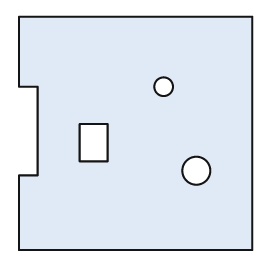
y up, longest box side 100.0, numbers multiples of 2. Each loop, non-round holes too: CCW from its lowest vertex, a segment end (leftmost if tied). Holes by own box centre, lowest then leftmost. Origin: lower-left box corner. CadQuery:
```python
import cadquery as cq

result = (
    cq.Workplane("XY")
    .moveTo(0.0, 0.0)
    .lineTo(100.0, 0.0)
    .lineTo(100.0, 100.0)
    .lineTo(0.0, 100.0)
    .lineTo(0.0, 70.0)
    .lineTo(8.0, 70.0)
    .lineTo(8.0, 32.0)
    .lineTo(0.0, 32.0)
    .close()
    .moveTo(76.0, 34.0)
    .circle(6.0)
    .moveTo(26.0, 38.0)
    .lineTo(38.0, 38.0)
    .lineTo(38.0, 54.0)
    .lineTo(26.0, 54.0)
    .close()
    .moveTo(62.0, 70.0)
    .circle(4.0)
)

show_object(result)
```